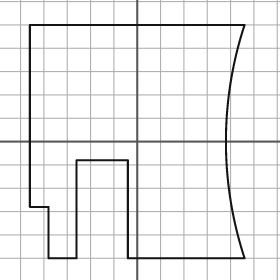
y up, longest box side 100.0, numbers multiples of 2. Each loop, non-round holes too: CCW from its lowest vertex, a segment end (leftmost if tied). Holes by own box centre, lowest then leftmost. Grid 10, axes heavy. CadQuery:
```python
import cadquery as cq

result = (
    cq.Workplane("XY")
    .moveTo(-38.0, -50.0)
    .lineTo(-26.0, -50.0)
    .lineTo(-26.0, -8.0)
    .lineTo(-4.0, -8.0)
    .lineTo(-4.0, -50.0)
    .lineTo(46.0, -50.0)
    .threePointArc((38.0, 0.0), (46.0, 50.0))
    .lineTo(-46.0, 50.0)
    .lineTo(-46.0, -28.0)
    .lineTo(-38.0, -28.0)
    .close()
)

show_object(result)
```